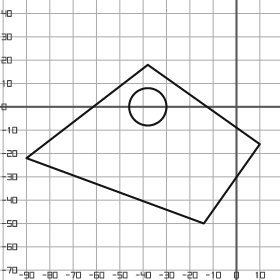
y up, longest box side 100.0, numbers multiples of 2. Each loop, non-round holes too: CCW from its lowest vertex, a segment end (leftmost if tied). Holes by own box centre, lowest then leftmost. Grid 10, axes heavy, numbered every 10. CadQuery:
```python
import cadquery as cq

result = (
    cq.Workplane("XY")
    .moveTo(-14.0, -50.0)
    .lineTo(10.0, -16.0)
    .lineTo(-38.0, 18.0)
    .lineTo(-90.0, -22.0)
    .close()
    .moveTo(-38.0, 0.0)
    .circle(8.0)
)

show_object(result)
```